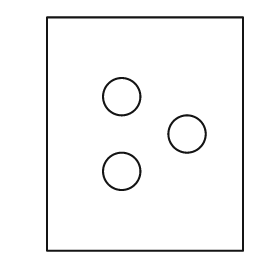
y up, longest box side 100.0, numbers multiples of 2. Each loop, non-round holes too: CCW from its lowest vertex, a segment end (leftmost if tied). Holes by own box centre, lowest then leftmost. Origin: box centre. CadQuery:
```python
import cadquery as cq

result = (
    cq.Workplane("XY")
    .moveTo(-42.0, -50.0)
    .lineTo(42.0, -50.0)
    .lineTo(42.0, 50.0)
    .lineTo(-42.0, 50.0)
    .close()
    .moveTo(-10.0, -16.0)
    .circle(8.0)
    .moveTo(18.0, 0.0)
    .circle(8.0)
    .moveTo(-10.0, 16.0)
    .circle(8.0)
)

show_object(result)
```